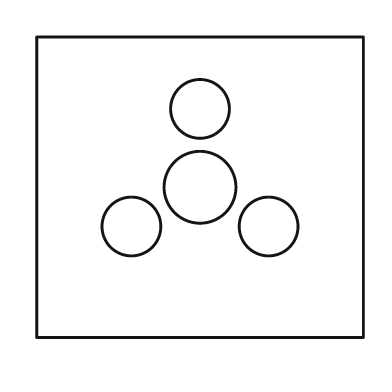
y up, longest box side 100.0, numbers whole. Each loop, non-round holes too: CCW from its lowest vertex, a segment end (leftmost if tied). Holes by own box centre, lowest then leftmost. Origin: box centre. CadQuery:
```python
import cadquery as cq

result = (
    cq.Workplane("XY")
    .moveTo(-50.0, -46.0)
    .lineTo(50.0, -46.0)
    .lineTo(50.0, 46.0)
    .lineTo(-50.0, 46.0)
    .close()
    .moveTo(-21.0, -12.0)
    .circle(9.0)
    .moveTo(21.0, -12.0)
    .circle(9.0)
    .moveTo(0.0, 0.0)
    .circle(11.0)
    .moveTo(0.0, 24.0)
    .circle(9.0)
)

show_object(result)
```